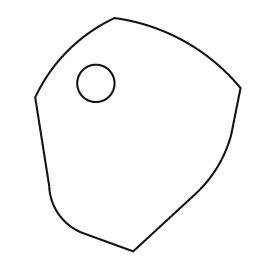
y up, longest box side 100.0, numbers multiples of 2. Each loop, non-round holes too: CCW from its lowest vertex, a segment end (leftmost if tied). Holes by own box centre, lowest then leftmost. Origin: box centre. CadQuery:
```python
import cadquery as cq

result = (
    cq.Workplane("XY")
    .moveTo(-2.0, -50.0)
    .lineTo(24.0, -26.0)
    .threePointArc((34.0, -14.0), (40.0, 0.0))
    .lineTo(44.0, 20.0)
    .threePointArc((20.0, 40.0), (-10.0, 50.0))
    .threePointArc((-30.0, 36.0), (-44.0, 16.0))
    .lineTo(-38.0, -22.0)
    .threePointArc((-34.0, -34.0), (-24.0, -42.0))
    .close()
    .moveTo(-18.0, 22.0)
    .circle(8.0)
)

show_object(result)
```